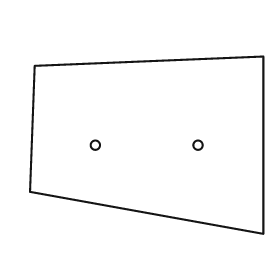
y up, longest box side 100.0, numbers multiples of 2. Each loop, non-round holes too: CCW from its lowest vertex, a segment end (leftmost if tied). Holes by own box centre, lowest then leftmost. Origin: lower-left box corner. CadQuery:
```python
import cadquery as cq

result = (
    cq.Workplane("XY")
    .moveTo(100.0, 0.0)
    .lineTo(100.0, 76.0)
    .lineTo(2.0, 72.0)
    .lineTo(0.0, 18.0)
    .close()
    .moveTo(28.0, 38.0)
    .circle(2.0)
    .moveTo(72.0, 38.0)
    .circle(2.0)
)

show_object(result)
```